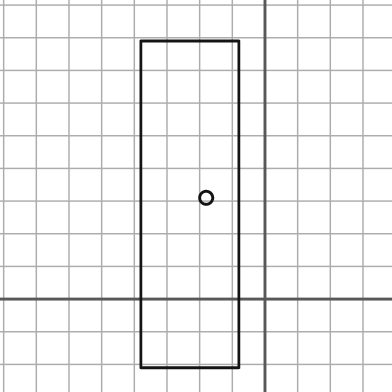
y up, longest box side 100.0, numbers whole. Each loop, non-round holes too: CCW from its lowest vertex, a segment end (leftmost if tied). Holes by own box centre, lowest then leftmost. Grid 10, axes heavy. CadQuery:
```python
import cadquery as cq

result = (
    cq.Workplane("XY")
    .moveTo(-38.0, -21.0)
    .lineTo(-8.0, -21.0)
    .lineTo(-8.0, 79.0)
    .lineTo(-38.0, 79.0)
    .close()
    .moveTo(-18.0, 31.0)
    .circle(2.0)
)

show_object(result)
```